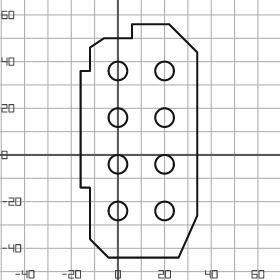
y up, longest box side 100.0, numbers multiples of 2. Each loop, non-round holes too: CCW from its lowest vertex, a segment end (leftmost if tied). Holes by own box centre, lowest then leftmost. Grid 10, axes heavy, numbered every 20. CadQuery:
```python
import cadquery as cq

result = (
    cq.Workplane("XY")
    .moveTo(-4.0, -44.0)
    .lineTo(26.0, -44.0)
    .lineTo(34.0, -26.0)
    .lineTo(34.0, 44.0)
    .lineTo(22.0, 56.0)
    .lineTo(6.0, 56.0)
    .lineTo(6.0, 50.0)
    .lineTo(-6.0, 50.0)
    .lineTo(-12.0, 46.0)
    .lineTo(-12.0, 36.0)
    .lineTo(-16.0, 36.0)
    .lineTo(-16.0, -14.0)
    .lineTo(-12.0, -14.0)
    .lineTo(-12.0, -36.0)
    .close()
    .moveTo(0.0, -24.0)
    .circle(4.0)
    .moveTo(20.0, -24.0)
    .circle(4.0)
    .moveTo(0.0, -4.0)
    .circle(4.0)
    .moveTo(20.0, -4.0)
    .circle(4.0)
    .moveTo(0.0, 16.0)
    .circle(4.0)
    .moveTo(20.0, 16.0)
    .circle(4.0)
    .moveTo(0.0, 36.0)
    .circle(4.0)
    .moveTo(20.0, 36.0)
    .circle(4.0)
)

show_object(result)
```